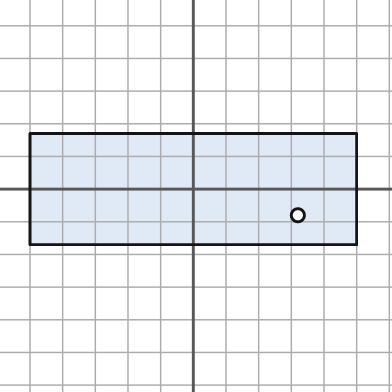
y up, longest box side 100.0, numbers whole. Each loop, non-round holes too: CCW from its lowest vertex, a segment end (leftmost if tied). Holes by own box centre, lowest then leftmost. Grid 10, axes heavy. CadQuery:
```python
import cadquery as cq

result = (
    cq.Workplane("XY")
    .moveTo(-50.0, -17.0)
    .lineTo(50.0, -17.0)
    .lineTo(50.0, 17.0)
    .lineTo(-50.0, 17.0)
    .close()
    .moveTo(32.0, -8.0)
    .circle(2.0)
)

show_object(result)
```